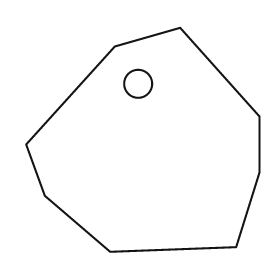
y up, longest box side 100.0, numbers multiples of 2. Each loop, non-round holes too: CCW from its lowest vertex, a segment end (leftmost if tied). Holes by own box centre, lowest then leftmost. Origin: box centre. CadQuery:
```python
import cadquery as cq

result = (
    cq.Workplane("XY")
    .moveTo(-14.0, -48.0)
    .lineTo(40.0, -46.0)
    .lineTo(50.0, -14.0)
    .lineTo(50.0, 10.0)
    .lineTo(16.0, 48.0)
    .lineTo(-12.0, 40.0)
    .lineTo(-50.0, -2.0)
    .lineTo(-42.0, -24.0)
    .close()
    .moveTo(-2.0, 24.0)
    .circle(6.0)
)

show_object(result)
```